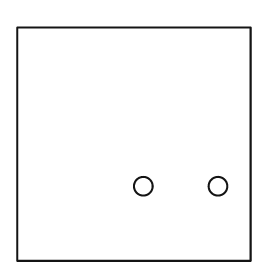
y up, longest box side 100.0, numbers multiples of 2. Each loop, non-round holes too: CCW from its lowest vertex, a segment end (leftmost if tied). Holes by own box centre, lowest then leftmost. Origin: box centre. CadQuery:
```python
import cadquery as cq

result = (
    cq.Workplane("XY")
    .moveTo(-50.0, -50.0)
    .lineTo(50.0, -50.0)
    .lineTo(50.0, 50.0)
    .lineTo(-50.0, 50.0)
    .close()
    .moveTo(4.0, -18.0)
    .circle(4.0)
    .moveTo(36.0, -18.0)
    .circle(4.0)
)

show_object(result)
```